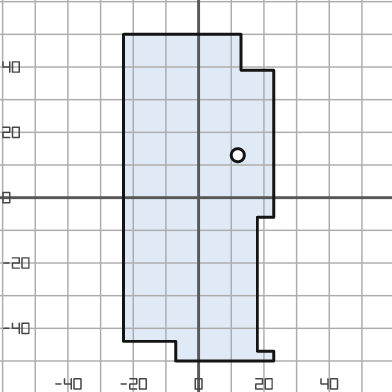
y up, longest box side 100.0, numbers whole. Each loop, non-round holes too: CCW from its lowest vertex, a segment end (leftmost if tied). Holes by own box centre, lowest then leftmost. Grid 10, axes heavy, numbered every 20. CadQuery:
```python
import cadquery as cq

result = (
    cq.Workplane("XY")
    .moveTo(-7.0, -50.0)
    .lineTo(23.0, -50.0)
    .lineTo(23.0, -47.0)
    .lineTo(18.0, -47.0)
    .lineTo(18.0, -6.0)
    .lineTo(23.0, -6.0)
    .lineTo(23.0, 39.0)
    .lineTo(13.0, 39.0)
    .lineTo(13.0, 50.0)
    .lineTo(-23.0, 50.0)
    .lineTo(-23.0, -44.0)
    .lineTo(-7.0, -44.0)
    .close()
    .moveTo(12.0, 13.0)
    .circle(2.0)
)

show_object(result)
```